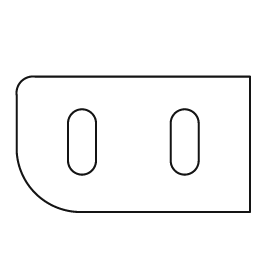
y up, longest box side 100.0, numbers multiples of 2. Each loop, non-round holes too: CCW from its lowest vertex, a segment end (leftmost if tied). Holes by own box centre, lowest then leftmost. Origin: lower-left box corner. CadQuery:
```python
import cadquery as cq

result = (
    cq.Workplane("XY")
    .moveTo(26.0, 0.0)
    .lineTo(100.0, 0.0)
    .lineTo(100.0, 58.0)
    .lineTo(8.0, 58.0)
    .threePointArc((2.0, 56.0), (0.0, 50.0))
    .lineTo(0.0, 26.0)
    .threePointArc((8.0, 8.0), (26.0, 0.0))
    .close()
    .moveTo(22.0, 22.0)
    .threePointArc((28.0, 16.0), (34.0, 22.0))
    .lineTo(34.0, 38.0)
    .threePointArc((28.0, 44.0), (22.0, 38.0))
    .close()
    .moveTo(66.0, 22.0)
    .threePointArc((72.0, 16.0), (78.0, 22.0))
    .lineTo(78.0, 38.0)
    .threePointArc((72.0, 44.0), (66.0, 38.0))
    .close()
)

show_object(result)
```